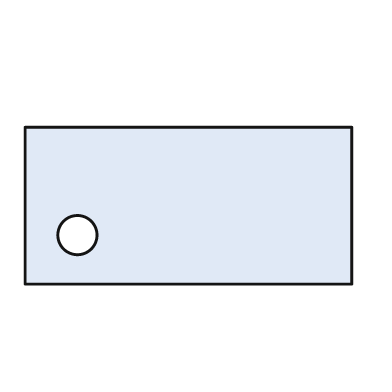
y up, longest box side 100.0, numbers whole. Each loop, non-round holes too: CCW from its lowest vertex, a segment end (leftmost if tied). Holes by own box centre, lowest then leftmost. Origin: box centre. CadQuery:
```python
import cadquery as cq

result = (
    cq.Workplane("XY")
    .moveTo(-50.0, -24.0)
    .lineTo(50.0, -24.0)
    .lineTo(50.0, 24.0)
    .lineTo(-50.0, 24.0)
    .close()
    .moveTo(-34.0, -9.0)
    .circle(6.0)
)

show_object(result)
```